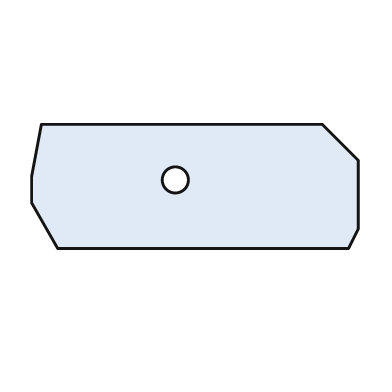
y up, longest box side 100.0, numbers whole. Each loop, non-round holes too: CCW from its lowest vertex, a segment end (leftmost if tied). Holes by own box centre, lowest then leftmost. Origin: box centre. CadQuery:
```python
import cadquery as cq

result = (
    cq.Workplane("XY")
    .moveTo(-42.0, -19.0)
    .lineTo(47.0, -19.0)
    .lineTo(50.0, -13.0)
    .lineTo(50.0, 8.0)
    .lineTo(39.0, 19.0)
    .lineTo(-47.0, 19.0)
    .lineTo(-50.0, 3.0)
    .lineTo(-50.0, -5.0)
    .close()
    .moveTo(-6.0, 2.0)
    .circle(4.0)
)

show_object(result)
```